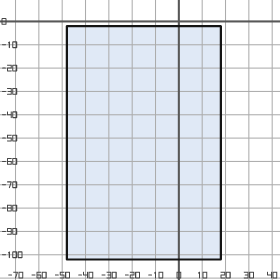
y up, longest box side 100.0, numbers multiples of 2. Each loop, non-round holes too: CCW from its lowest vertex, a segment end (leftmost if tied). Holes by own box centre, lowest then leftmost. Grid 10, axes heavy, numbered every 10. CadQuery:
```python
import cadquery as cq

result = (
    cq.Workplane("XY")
    .moveTo(-48.0, -102.0)
    .lineTo(18.0, -102.0)
    .lineTo(18.0, -2.0)
    .lineTo(-48.0, -2.0)
    .close()
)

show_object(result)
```